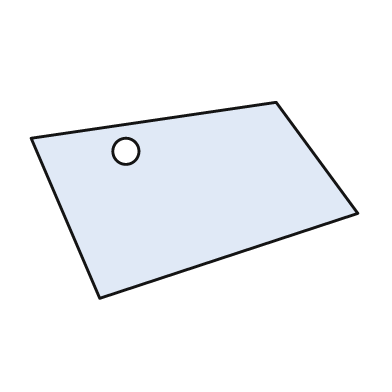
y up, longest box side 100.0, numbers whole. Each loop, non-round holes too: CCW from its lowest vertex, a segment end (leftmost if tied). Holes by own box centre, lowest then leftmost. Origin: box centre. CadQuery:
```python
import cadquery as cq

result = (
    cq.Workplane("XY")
    .moveTo(-29.0, -30.0)
    .lineTo(50.0, -4.0)
    .lineTo(25.0, 30.0)
    .lineTo(-50.0, 19.0)
    .close()
    .moveTo(-21.0, 15.0)
    .circle(4.0)
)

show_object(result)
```